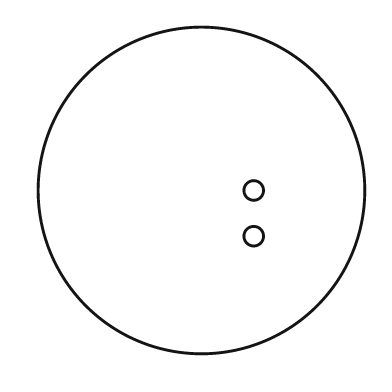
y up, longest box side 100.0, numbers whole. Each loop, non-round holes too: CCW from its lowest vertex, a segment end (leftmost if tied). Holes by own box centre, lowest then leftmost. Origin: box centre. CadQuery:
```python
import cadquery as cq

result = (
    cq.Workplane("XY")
    .moveTo(0.0, 0.0)
    .circle(50.0)
    .moveTo(16.0, -14.0)
    .circle(3.0)
    .moveTo(16.0, 0.0)
    .circle(3.0)
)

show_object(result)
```